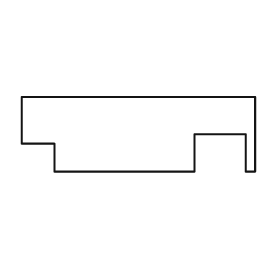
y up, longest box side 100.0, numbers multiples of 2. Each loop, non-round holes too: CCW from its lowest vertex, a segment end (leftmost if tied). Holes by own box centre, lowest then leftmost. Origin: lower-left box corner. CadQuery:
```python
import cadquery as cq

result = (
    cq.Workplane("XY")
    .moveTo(14.0, 0.0)
    .lineTo(74.0, 0.0)
    .lineTo(74.0, 16.0)
    .lineTo(96.0, 16.0)
    .lineTo(96.0, 0.0)
    .lineTo(100.0, 0.0)
    .lineTo(100.0, 32.0)
    .lineTo(0.0, 32.0)
    .lineTo(0.0, 12.0)
    .lineTo(14.0, 12.0)
    .close()
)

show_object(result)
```